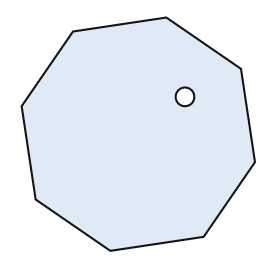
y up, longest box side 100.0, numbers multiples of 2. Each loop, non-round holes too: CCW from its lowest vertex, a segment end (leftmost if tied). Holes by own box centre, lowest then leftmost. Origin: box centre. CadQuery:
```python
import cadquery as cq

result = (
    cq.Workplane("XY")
    .moveTo(-12.0, -50.0)
    .lineTo(28.0, -44.0)
    .lineTo(50.0, -12.0)
    .lineTo(44.0, 28.0)
    .lineTo(12.0, 50.0)
    .lineTo(-28.0, 44.0)
    .lineTo(-50.0, 12.0)
    .lineTo(-44.0, -28.0)
    .close()
    .moveTo(20.0, 16.0)
    .circle(4.0)
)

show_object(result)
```